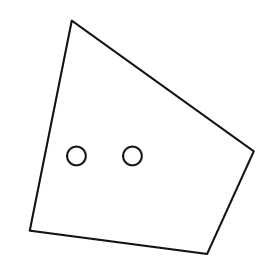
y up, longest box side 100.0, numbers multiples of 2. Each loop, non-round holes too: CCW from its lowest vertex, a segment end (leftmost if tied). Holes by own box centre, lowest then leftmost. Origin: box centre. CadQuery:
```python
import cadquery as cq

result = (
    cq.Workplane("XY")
    .moveTo(28.0, -50.0)
    .lineTo(48.0, -6.0)
    .lineTo(-30.0, 50.0)
    .lineTo(-48.0, -40.0)
    .close()
    .moveTo(-28.0, -8.0)
    .circle(4.0)
    .moveTo(-4.0, -8.0)
    .circle(4.0)
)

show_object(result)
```